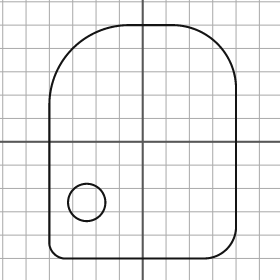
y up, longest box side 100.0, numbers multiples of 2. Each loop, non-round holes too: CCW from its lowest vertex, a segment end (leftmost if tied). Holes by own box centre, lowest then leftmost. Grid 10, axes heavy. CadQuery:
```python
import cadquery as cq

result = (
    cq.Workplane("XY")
    .moveTo(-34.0, -50.0)
    .lineTo(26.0, -50.0)
    .threePointArc((36.0, -46.0), (40.0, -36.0))
    .lineTo(40.0, 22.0)
    .threePointArc((32.0, 42.0), (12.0, 50.0))
    .lineTo(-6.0, 50.0)
    .threePointArc((-30.0, 40.0), (-40.0, 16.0))
    .lineTo(-40.0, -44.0)
    .threePointArc((-38.0, -48.0), (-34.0, -50.0))
    .close()
    .moveTo(-24.0, -26.0)
    .circle(8.0)
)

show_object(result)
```